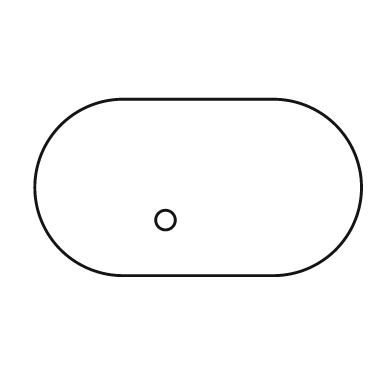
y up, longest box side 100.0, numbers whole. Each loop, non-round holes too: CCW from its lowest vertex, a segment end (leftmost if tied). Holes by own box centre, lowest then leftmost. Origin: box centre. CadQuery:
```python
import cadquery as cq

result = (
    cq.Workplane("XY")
    .moveTo(-23.0, -27.0)
    .lineTo(23.0, -27.0)
    .threePointArc((50.0, 0.0), (23.0, 27.0))
    .lineTo(-23.0, 27.0)
    .threePointArc((-50.0, 0.0), (-23.0, -27.0))
    .close()
    .moveTo(-10.0, -10.0)
    .circle(3.0)
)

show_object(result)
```